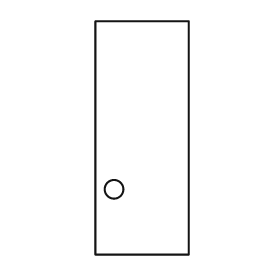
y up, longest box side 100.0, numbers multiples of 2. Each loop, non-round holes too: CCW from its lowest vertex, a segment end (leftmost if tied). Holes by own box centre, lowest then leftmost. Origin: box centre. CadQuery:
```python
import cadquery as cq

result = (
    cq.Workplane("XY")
    .moveTo(-20.0, -50.0)
    .lineTo(20.0, -50.0)
    .lineTo(20.0, 50.0)
    .lineTo(-20.0, 50.0)
    .close()
    .moveTo(-12.0, -22.0)
    .circle(4.0)
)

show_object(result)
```